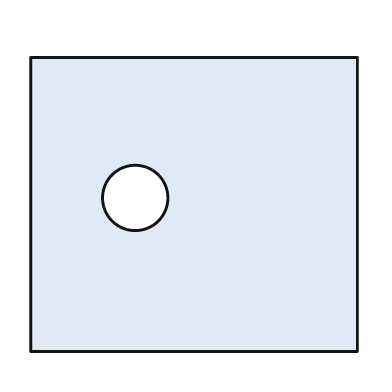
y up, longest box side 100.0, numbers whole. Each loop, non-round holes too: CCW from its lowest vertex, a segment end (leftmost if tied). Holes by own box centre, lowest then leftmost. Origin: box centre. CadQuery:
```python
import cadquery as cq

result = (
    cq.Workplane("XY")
    .moveTo(-50.0, -45.0)
    .lineTo(50.0, -45.0)
    .lineTo(50.0, 45.0)
    .lineTo(-50.0, 45.0)
    .close()
    .moveTo(-18.0, 2.0)
    .circle(10.0)
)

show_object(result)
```